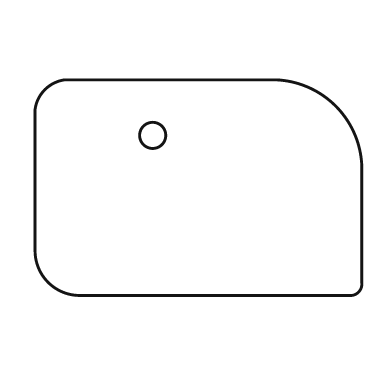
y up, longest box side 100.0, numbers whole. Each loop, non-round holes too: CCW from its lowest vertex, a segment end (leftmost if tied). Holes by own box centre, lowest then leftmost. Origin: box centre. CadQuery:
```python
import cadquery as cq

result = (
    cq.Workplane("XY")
    .moveTo(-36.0, -33.0)
    .lineTo(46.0, -33.0)
    .threePointArc((49.0, -32.0), (50.0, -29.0))
    .lineTo(50.0, 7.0)
    .threePointArc((42.0, 25.0), (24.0, 33.0))
    .lineTo(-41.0, 33.0)
    .threePointArc((-47.0, 30.0), (-50.0, 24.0))
    .lineTo(-50.0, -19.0)
    .threePointArc((-46.0, -29.0), (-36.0, -33.0))
    .close()
    .moveTo(-14.0, 16.0)
    .circle(4.0)
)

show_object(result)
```